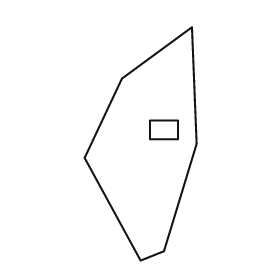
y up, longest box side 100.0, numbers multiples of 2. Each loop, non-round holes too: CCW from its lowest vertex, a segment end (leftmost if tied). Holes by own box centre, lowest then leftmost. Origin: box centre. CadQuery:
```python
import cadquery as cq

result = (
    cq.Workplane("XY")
    .moveTo(0.0, -50.0)
    .lineTo(10.0, -46.0)
    .lineTo(24.0, 0.0)
    .lineTo(22.0, 50.0)
    .lineTo(-8.0, 28.0)
    .lineTo(-24.0, -6.0)
    .close()
    .moveTo(4.0, 2.0)
    .lineTo(16.0, 2.0)
    .lineTo(16.0, 10.0)
    .lineTo(4.0, 10.0)
    .close()
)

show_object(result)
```